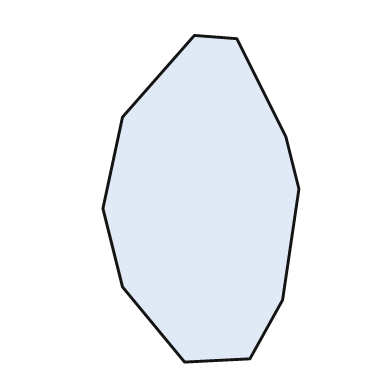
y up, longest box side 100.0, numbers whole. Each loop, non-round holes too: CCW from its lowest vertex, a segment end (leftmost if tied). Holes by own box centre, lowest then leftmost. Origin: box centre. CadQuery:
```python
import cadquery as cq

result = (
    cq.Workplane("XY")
    .moveTo(-5.0, -50.0)
    .lineTo(15.0, -49.0)
    .lineTo(25.0, -31.0)
    .lineTo(30.0, 3.0)
    .lineTo(26.0, 19.0)
    .lineTo(11.0, 49.0)
    .lineTo(-2.0, 50.0)
    .lineTo(-24.0, 25.0)
    .lineTo(-30.0, -3.0)
    .lineTo(-24.0, -27.0)
    .close()
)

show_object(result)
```